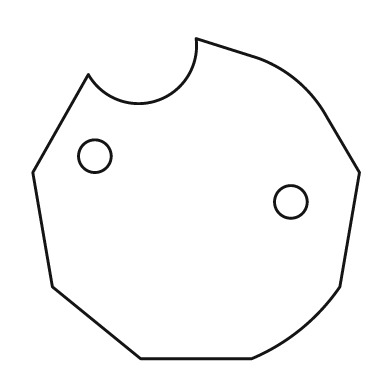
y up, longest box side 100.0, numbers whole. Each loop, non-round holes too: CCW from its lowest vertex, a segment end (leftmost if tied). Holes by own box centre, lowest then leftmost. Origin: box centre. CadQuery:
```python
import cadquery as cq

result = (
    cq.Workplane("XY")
    .moveTo(-17.0, -49.0)
    .lineTo(17.0, -49.0)
    .threePointArc((32.0, -40.0), (44.0, -27.0))
    .lineTo(50.0, 8.0)
    .lineTo(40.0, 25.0)
    .threePointArc((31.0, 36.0), (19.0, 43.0))
    .lineTo(0.0, 49.0)
    .threePointArc((-12.0, 30.0), (-33.0, 38.0))
    .lineTo(-50.0, 8.0)
    .lineTo(-44.0, -27.0)
    .close()
    .moveTo(29.0, -1.0)
    .circle(5.0)
    .moveTo(-31.0, 13.0)
    .circle(5.0)
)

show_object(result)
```